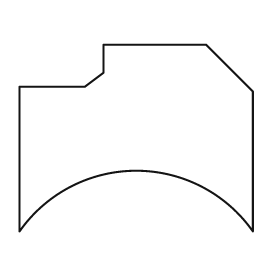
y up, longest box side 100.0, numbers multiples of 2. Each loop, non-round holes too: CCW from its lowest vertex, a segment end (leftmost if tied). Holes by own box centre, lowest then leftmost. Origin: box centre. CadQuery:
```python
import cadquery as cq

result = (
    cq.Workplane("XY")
    .moveTo(-50.0, -40.0)
    .threePointArc((0.0, -14.0), (50.0, -40.0))
    .lineTo(50.0, 20.0)
    .lineTo(30.0, 40.0)
    .lineTo(-14.0, 40.0)
    .lineTo(-14.0, 28.0)
    .lineTo(-22.0, 22.0)
    .lineTo(-50.0, 22.0)
    .close()
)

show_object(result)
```